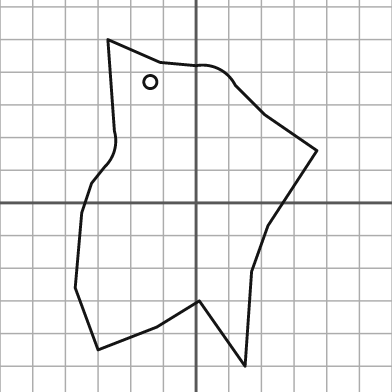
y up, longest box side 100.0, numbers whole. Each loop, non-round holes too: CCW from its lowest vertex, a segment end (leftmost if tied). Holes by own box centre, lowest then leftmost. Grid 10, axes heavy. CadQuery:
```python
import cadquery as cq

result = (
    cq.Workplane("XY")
    .moveTo(15.0, -50.0)
    .lineTo(17.0, -21.0)
    .lineTo(22.0, -7.0)
    .lineTo(37.0, 16.0)
    .lineTo(21.0, 27.0)
    .lineTo(12.0, 36.0)
    .threePointArc((7.0, 41.0), (0.0, 42.0))
    .lineTo(-11.0, 43.0)
    .lineTo(-27.0, 50.0)
    .lineTo(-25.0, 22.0)
    .threePointArc((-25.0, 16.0), (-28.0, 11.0))
    .lineTo(-32.0, 6.0)
    .lineTo(-35.0, -3.0)
    .lineTo(-37.0, -26.0)
    .lineTo(-30.0, -45.0)
    .lineTo(-12.0, -38.0)
    .lineTo(1.0, -30.0)
    .close()
    .moveTo(-14.0, 37.0)
    .circle(2.0)
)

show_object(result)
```